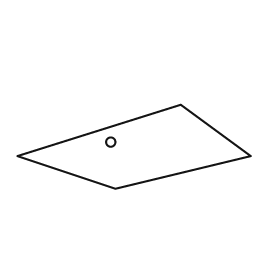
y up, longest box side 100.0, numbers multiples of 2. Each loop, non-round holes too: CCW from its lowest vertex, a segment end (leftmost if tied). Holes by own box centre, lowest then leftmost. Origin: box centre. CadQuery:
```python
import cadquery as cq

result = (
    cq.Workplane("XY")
    .moveTo(-8.0, -18.0)
    .lineTo(50.0, -4.0)
    .lineTo(20.0, 18.0)
    .lineTo(-50.0, -4.0)
    .close()
    .moveTo(-10.0, 2.0)
    .circle(2.0)
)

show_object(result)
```